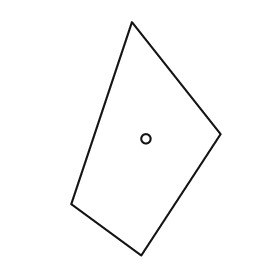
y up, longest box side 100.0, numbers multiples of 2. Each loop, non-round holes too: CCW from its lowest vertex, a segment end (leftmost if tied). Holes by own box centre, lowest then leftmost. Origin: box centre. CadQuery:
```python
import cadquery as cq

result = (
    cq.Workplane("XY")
    .moveTo(-2.0, -50.0)
    .lineTo(32.0, 2.0)
    .lineTo(-6.0, 50.0)
    .lineTo(-32.0, -28.0)
    .close()
    .moveTo(0.0, 0.0)
    .circle(2.0)
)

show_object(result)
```